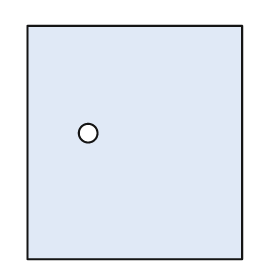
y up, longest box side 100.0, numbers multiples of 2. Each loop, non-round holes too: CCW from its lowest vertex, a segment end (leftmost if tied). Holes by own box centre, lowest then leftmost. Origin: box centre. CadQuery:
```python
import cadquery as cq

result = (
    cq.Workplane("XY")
    .moveTo(-46.0, -50.0)
    .lineTo(46.0, -50.0)
    .lineTo(46.0, 50.0)
    .lineTo(-46.0, 50.0)
    .close()
    .moveTo(-20.0, 4.0)
    .circle(4.0)
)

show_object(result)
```